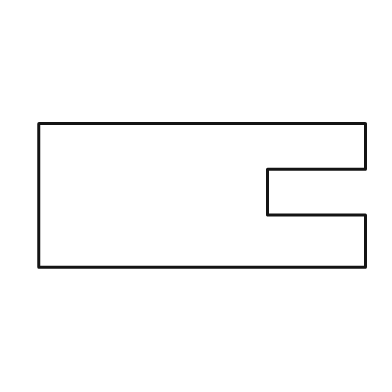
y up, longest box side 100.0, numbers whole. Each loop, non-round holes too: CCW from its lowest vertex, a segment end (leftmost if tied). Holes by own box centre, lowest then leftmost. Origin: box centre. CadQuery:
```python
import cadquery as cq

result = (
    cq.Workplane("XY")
    .moveTo(-50.0, -22.0)
    .lineTo(50.0, -22.0)
    .lineTo(50.0, -6.0)
    .lineTo(20.0, -6.0)
    .lineTo(20.0, 8.0)
    .lineTo(50.0, 8.0)
    .lineTo(50.0, 22.0)
    .lineTo(-50.0, 22.0)
    .close()
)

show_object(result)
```